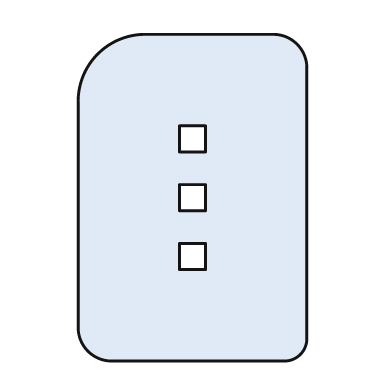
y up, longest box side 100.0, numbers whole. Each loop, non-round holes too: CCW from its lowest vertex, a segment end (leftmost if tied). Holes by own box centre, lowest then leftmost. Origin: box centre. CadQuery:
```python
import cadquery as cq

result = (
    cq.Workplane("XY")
    .moveTo(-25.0, -50.0)
    .lineTo(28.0, -50.0)
    .threePointArc((33.0, -48.0), (35.0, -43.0))
    .lineTo(35.0, 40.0)
    .threePointArc((32.0, 47.0), (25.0, 50.0))
    .lineTo(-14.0, 50.0)
    .threePointArc((-29.0, 44.0), (-35.0, 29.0))
    .lineTo(-35.0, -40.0)
    .threePointArc((-32.0, -47.0), (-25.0, -50.0))
    .close()
    .moveTo(-4.0, -22.0)
    .lineTo(4.0, -22.0)
    .lineTo(4.0, -14.0)
    .lineTo(-4.0, -14.0)
    .close()
    .moveTo(-4.0, -4.0)
    .lineTo(4.0, -4.0)
    .lineTo(4.0, 4.0)
    .lineTo(-4.0, 4.0)
    .close()
    .moveTo(-4.0, 14.0)
    .lineTo(4.0, 14.0)
    .lineTo(4.0, 22.0)
    .lineTo(-4.0, 22.0)
    .close()
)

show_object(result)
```